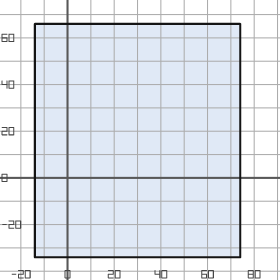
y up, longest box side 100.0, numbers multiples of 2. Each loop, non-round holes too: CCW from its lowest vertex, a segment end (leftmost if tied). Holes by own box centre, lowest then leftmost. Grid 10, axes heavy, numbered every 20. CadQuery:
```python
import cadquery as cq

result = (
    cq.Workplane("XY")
    .moveTo(-14.0, -34.0)
    .lineTo(74.0, -34.0)
    .lineTo(74.0, 66.0)
    .lineTo(-14.0, 66.0)
    .close()
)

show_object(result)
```